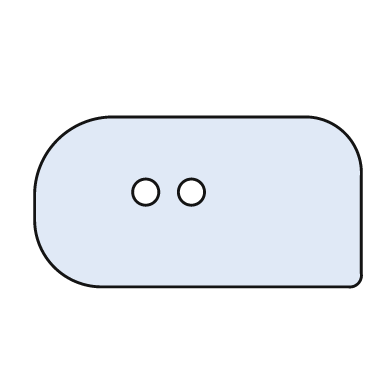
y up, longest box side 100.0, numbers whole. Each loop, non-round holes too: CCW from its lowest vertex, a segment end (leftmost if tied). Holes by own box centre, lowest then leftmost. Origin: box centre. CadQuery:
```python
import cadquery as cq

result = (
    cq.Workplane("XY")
    .moveTo(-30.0, -26.0)
    .lineTo(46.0, -26.0)
    .threePointArc((49.0, -25.0), (50.0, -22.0))
    .lineTo(50.0, 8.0)
    .threePointArc((45.0, 21.0), (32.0, 26.0))
    .lineTo(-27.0, 26.0)
    .threePointArc((-43.0, 19.0), (-50.0, 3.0))
    .lineTo(-50.0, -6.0)
    .threePointArc((-44.0, -20.0), (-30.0, -26.0))
    .close()
    .moveTo(-16.0, 3.0)
    .circle(4.0)
    .moveTo(-2.0, 3.0)
    .circle(4.0)
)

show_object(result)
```